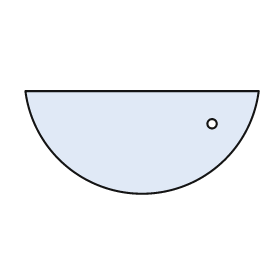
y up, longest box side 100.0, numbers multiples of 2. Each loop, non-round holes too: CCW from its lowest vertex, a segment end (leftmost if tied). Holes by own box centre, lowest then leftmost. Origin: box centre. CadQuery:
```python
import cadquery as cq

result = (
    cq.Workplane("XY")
    .moveTo(-50.0, 22.0)
    .threePointArc((0.0, -22.0), (50.0, 22.0))
    .close()
    .moveTo(30.0, 8.0)
    .circle(2.0)
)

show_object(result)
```